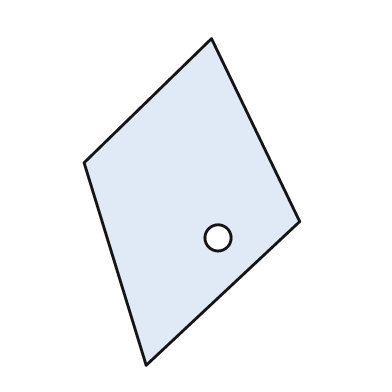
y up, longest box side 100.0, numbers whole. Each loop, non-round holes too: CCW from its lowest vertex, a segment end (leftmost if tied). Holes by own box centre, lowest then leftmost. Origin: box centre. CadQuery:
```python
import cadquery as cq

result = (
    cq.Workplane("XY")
    .moveTo(-14.0, -50.0)
    .lineTo(33.0, -6.0)
    .lineTo(6.0, 50.0)
    .lineTo(-33.0, 12.0)
    .close()
    .moveTo(8.0, -11.0)
    .circle(4.0)
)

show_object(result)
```